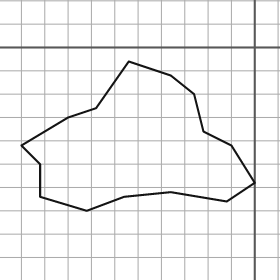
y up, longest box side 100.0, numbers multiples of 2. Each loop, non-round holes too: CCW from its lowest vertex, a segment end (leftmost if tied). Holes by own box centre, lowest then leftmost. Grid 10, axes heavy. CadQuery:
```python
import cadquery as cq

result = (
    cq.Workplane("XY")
    .moveTo(-72.0, -70.0)
    .lineTo(-56.0, -64.0)
    .lineTo(-36.0, -62.0)
    .lineTo(-12.0, -66.0)
    .lineTo(0.0, -58.0)
    .lineTo(-10.0, -42.0)
    .lineTo(-22.0, -36.0)
    .lineTo(-26.0, -20.0)
    .lineTo(-36.0, -12.0)
    .lineTo(-54.0, -6.0)
    .lineTo(-68.0, -26.0)
    .lineTo(-80.0, -30.0)
    .lineTo(-100.0, -42.0)
    .lineTo(-92.0, -50.0)
    .lineTo(-92.0, -64.0)
    .close()
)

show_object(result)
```